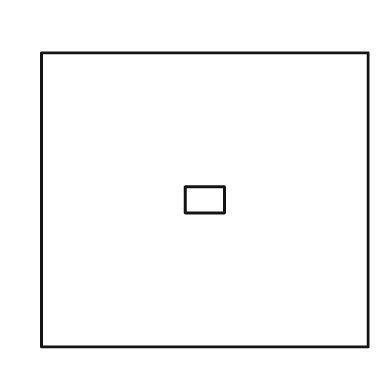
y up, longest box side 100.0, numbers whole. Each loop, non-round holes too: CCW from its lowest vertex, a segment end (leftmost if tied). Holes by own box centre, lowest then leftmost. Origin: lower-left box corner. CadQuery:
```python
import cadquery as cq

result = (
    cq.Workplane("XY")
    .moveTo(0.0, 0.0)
    .lineTo(100.0, 0.0)
    .lineTo(100.0, 90.0)
    .lineTo(0.0, 90.0)
    .close()
    .moveTo(44.0, 41.0)
    .lineTo(56.0, 41.0)
    .lineTo(56.0, 49.0)
    .lineTo(44.0, 49.0)
    .close()
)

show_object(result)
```